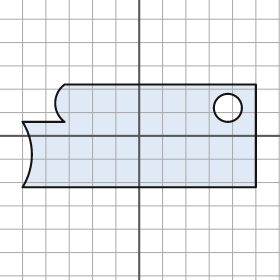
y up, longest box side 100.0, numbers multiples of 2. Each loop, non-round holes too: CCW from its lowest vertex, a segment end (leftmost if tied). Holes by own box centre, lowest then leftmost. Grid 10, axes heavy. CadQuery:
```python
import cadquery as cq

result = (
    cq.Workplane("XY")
    .moveTo(-50.0, -22.0)
    .lineTo(50.0, -22.0)
    .lineTo(50.0, 22.0)
    .lineTo(-32.0, 22.0)
    .threePointArc((-36.0, 14.0), (-32.0, 6.0))
    .lineTo(-50.0, 6.0)
    .threePointArc((-46.0, -8.0), (-50.0, -22.0))
    .close()
    .moveTo(38.0, 12.0)
    .circle(6.0)
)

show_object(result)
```